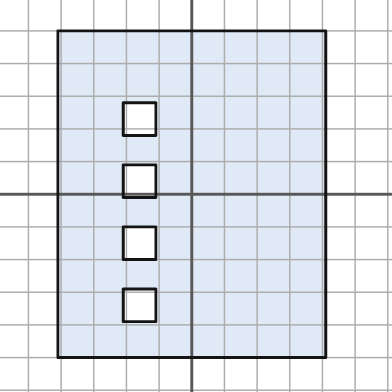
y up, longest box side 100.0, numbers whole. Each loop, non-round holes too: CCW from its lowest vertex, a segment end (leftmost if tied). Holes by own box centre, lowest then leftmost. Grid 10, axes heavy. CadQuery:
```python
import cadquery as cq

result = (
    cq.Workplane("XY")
    .moveTo(-41.0, -50.0)
    .lineTo(41.0, -50.0)
    .lineTo(41.0, 50.0)
    .lineTo(-41.0, 50.0)
    .close()
    .moveTo(-21.0, -39.0)
    .lineTo(-11.0, -39.0)
    .lineTo(-11.0, -29.0)
    .lineTo(-21.0, -29.0)
    .close()
    .moveTo(-21.0, -20.0)
    .lineTo(-11.0, -20.0)
    .lineTo(-11.0, -10.0)
    .lineTo(-21.0, -10.0)
    .close()
    .moveTo(-21.0, -1.0)
    .lineTo(-11.0, -1.0)
    .lineTo(-11.0, 9.0)
    .lineTo(-21.0, 9.0)
    .close()
    .moveTo(-21.0, 18.0)
    .lineTo(-11.0, 18.0)
    .lineTo(-11.0, 28.0)
    .lineTo(-21.0, 28.0)
    .close()
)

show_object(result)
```